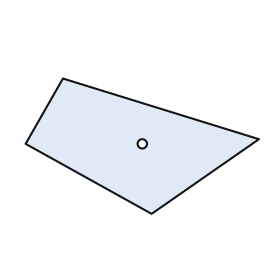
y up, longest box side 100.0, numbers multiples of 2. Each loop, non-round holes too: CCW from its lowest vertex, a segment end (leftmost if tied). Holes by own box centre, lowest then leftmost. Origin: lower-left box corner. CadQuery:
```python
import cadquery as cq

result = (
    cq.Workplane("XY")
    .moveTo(54.0, 0.0)
    .lineTo(100.0, 32.0)
    .lineTo(16.0, 58.0)
    .lineTo(0.0, 30.0)
    .close()
    .moveTo(50.0, 30.0)
    .circle(2.0)
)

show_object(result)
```